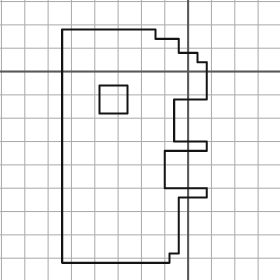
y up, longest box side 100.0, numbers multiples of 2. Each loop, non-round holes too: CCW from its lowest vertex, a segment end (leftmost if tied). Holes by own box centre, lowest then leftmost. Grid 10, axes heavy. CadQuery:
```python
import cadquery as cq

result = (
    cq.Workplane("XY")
    .moveTo(-54.0, -82.0)
    .lineTo(-8.0, -82.0)
    .lineTo(-8.0, -78.0)
    .lineTo(-4.0, -78.0)
    .lineTo(-4.0, -54.0)
    .lineTo(8.0, -54.0)
    .lineTo(8.0, -50.0)
    .lineTo(-10.0, -50.0)
    .lineTo(-10.0, -34.0)
    .lineTo(8.0, -34.0)
    .lineTo(8.0, -30.0)
    .lineTo(-6.0, -30.0)
    .lineTo(-6.0, -12.0)
    .lineTo(8.0, -12.0)
    .lineTo(8.0, 4.0)
    .lineTo(4.0, 4.0)
    .lineTo(4.0, 8.0)
    .lineTo(-4.0, 8.0)
    .lineTo(-4.0, 14.0)
    .lineTo(-14.0, 14.0)
    .lineTo(-14.0, 18.0)
    .lineTo(-54.0, 18.0)
    .close()
    .moveTo(-38.0, -18.0)
    .lineTo(-26.0, -18.0)
    .lineTo(-26.0, -6.0)
    .lineTo(-38.0, -6.0)
    .close()
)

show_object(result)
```